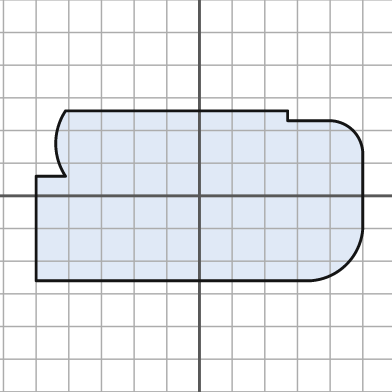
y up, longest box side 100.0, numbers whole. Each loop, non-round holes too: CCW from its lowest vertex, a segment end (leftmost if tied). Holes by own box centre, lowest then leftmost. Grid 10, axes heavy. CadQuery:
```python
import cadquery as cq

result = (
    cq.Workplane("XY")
    .moveTo(-50.0, -26.0)
    .lineTo(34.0, -26.0)
    .threePointArc((45.0, -21.0), (50.0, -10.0))
    .lineTo(50.0, 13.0)
    .threePointArc((47.0, 20.0), (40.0, 23.0))
    .lineTo(27.0, 23.0)
    .lineTo(27.0, 26.0)
    .lineTo(-41.0, 26.0)
    .threePointArc((-44.0, 16.0), (-41.0, 6.0))
    .lineTo(-50.0, 6.0)
    .close()
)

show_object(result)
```